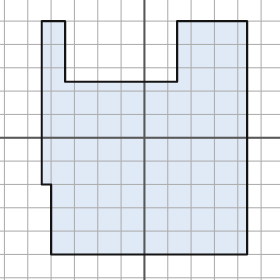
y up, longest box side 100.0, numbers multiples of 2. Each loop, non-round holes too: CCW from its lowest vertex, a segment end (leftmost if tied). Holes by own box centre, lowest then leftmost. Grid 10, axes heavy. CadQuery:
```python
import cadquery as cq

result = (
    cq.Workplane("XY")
    .moveTo(-40.0, -50.0)
    .lineTo(44.0, -50.0)
    .lineTo(44.0, 50.0)
    .lineTo(14.0, 50.0)
    .lineTo(14.0, 24.0)
    .lineTo(-34.0, 24.0)
    .lineTo(-34.0, 50.0)
    .lineTo(-44.0, 50.0)
    .lineTo(-44.0, -20.0)
    .lineTo(-40.0, -20.0)
    .close()
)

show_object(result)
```